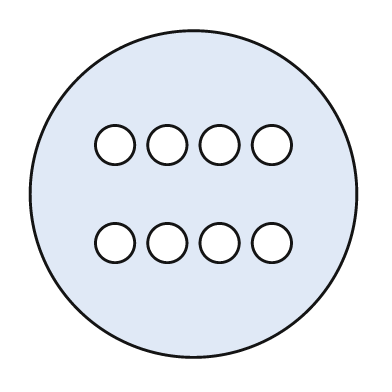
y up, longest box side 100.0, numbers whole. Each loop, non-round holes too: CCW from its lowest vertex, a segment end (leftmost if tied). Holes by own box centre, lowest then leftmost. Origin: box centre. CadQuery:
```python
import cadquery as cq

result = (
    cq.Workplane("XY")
    .moveTo(0.0, 0.0)
    .circle(50.0)
    .moveTo(-24.0, -15.0)
    .circle(6.0)
    .moveTo(-8.0, -15.0)
    .circle(6.0)
    .moveTo(8.0, -15.0)
    .circle(6.0)
    .moveTo(24.0, -15.0)
    .circle(6.0)
    .moveTo(-24.0, 15.0)
    .circle(6.0)
    .moveTo(-8.0, 15.0)
    .circle(6.0)
    .moveTo(8.0, 15.0)
    .circle(6.0)
    .moveTo(24.0, 15.0)
    .circle(6.0)
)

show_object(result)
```